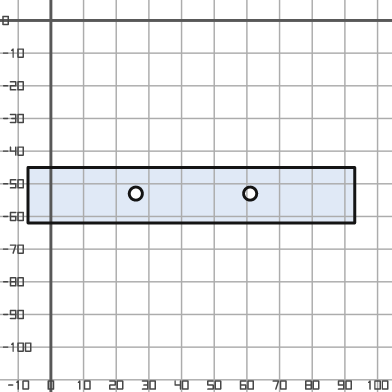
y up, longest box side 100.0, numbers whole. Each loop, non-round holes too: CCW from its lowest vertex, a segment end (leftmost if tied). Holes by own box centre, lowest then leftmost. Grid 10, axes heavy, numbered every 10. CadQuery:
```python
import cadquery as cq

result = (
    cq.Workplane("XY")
    .moveTo(-7.0, -62.0)
    .lineTo(93.0, -62.0)
    .lineTo(93.0, -45.0)
    .lineTo(-7.0, -45.0)
    .close()
    .moveTo(26.0, -53.0)
    .circle(2.0)
    .moveTo(61.0, -53.0)
    .circle(2.0)
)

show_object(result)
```